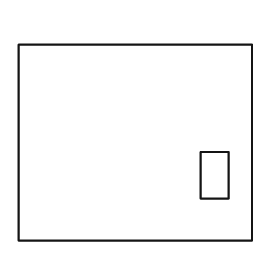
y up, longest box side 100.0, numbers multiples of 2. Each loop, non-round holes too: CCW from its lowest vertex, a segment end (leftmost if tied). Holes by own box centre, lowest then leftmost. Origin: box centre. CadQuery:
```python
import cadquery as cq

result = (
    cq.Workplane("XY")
    .moveTo(-50.0, -42.0)
    .lineTo(50.0, -42.0)
    .lineTo(50.0, 42.0)
    .lineTo(-50.0, 42.0)
    .close()
    .moveTo(28.0, -24.0)
    .lineTo(40.0, -24.0)
    .lineTo(40.0, -4.0)
    .lineTo(28.0, -4.0)
    .close()
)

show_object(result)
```